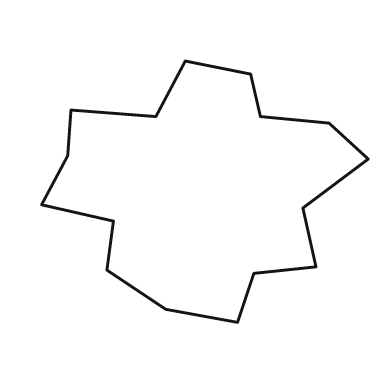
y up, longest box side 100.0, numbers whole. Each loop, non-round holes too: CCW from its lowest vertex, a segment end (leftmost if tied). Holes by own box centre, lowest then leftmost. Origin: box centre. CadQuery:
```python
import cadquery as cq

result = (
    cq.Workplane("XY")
    .moveTo(10.0, -40.0)
    .lineTo(15.0, -25.0)
    .lineTo(34.0, -23.0)
    .lineTo(30.0, -5.0)
    .lineTo(50.0, 10.0)
    .lineTo(38.0, 21.0)
    .lineTo(17.0, 23.0)
    .lineTo(14.0, 36.0)
    .lineTo(-6.0, 40.0)
    .lineTo(-15.0, 23.0)
    .lineTo(-41.0, 25.0)
    .lineTo(-42.0, 11.0)
    .lineTo(-50.0, -4.0)
    .lineTo(-28.0, -9.0)
    .lineTo(-30.0, -24.0)
    .lineTo(-12.0, -36.0)
    .close()
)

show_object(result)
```